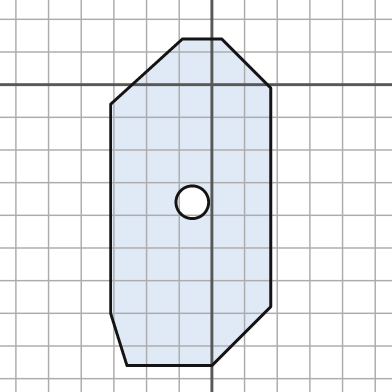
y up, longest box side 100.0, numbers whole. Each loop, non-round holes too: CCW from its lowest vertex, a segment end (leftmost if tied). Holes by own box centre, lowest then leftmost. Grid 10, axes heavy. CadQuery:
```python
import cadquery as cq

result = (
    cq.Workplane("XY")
    .moveTo(-26.0, -86.0)
    .lineTo(0.0, -86.0)
    .lineTo(18.0, -68.0)
    .lineTo(18.0, -1.0)
    .lineTo(3.0, 14.0)
    .lineTo(-9.0, 14.0)
    .lineTo(-31.0, -6.0)
    .lineTo(-31.0, -70.0)
    .close()
    .moveTo(-6.0, -36.0)
    .circle(5.0)
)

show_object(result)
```